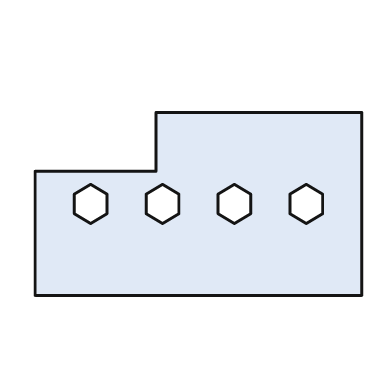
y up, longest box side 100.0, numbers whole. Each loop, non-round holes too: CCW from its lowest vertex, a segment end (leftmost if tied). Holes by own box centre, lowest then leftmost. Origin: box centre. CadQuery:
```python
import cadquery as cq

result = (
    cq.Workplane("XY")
    .moveTo(-50.0, -28.0)
    .lineTo(50.0, -28.0)
    .lineTo(50.0, 28.0)
    .lineTo(-13.0, 28.0)
    .lineTo(-13.0, 10.0)
    .lineTo(-50.0, 10.0)
    .close()
    .moveTo(-33.0, -6.0)
    .lineTo(-28.0, -3.0)
    .lineTo(-28.0, 3.0)
    .lineTo(-33.0, 6.0)
    .lineTo(-38.0, 3.0)
    .lineTo(-38.0, -3.0)
    .close()
    .moveTo(-11.0, -6.0)
    .lineTo(-6.0, -3.0)
    .lineTo(-6.0, 3.0)
    .lineTo(-11.0, 6.0)
    .lineTo(-16.0, 3.0)
    .lineTo(-16.0, -3.0)
    .close()
    .moveTo(11.0, -6.0)
    .lineTo(16.0, -3.0)
    .lineTo(16.0, 3.0)
    .lineTo(11.0, 6.0)
    .lineTo(6.0, 3.0)
    .lineTo(6.0, -3.0)
    .close()
    .moveTo(33.0, -6.0)
    .lineTo(38.0, -3.0)
    .lineTo(38.0, 3.0)
    .lineTo(33.0, 6.0)
    .lineTo(28.0, 3.0)
    .lineTo(28.0, -3.0)
    .close()
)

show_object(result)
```